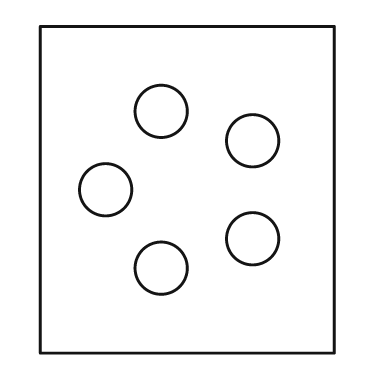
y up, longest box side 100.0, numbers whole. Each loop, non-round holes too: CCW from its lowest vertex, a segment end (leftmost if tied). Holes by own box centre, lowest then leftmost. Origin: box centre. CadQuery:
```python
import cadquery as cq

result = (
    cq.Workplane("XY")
    .moveTo(-45.0, -50.0)
    .lineTo(45.0, -50.0)
    .lineTo(45.0, 50.0)
    .lineTo(-45.0, 50.0)
    .close()
    .moveTo(-8.0, -24.0)
    .circle(8.0)
    .moveTo(20.0, -15.0)
    .circle(8.0)
    .moveTo(-25.0, 0.0)
    .circle(8.0)
    .moveTo(20.0, 15.0)
    .circle(8.0)
    .moveTo(-8.0, 24.0)
    .circle(8.0)
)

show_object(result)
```